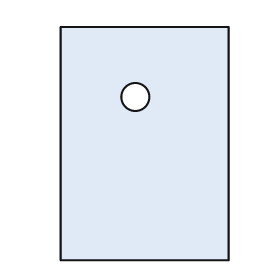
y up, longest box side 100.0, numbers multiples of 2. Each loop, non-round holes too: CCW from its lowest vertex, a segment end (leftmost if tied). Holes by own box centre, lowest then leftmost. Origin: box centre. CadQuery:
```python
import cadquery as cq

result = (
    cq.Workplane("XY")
    .moveTo(-36.0, -50.0)
    .lineTo(36.0, -50.0)
    .lineTo(36.0, 50.0)
    .lineTo(-36.0, 50.0)
    .close()
    .moveTo(-4.0, 20.0)
    .circle(6.0)
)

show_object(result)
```